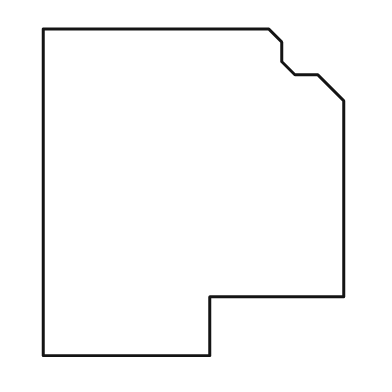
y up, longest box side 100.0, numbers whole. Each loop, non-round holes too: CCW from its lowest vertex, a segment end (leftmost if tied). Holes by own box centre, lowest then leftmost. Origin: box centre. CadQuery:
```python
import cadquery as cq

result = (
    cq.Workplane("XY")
    .moveTo(-46.0, -50.0)
    .lineTo(5.0, -50.0)
    .lineTo(5.0, -32.0)
    .lineTo(46.0, -32.0)
    .lineTo(46.0, 28.0)
    .lineTo(38.0, 36.0)
    .lineTo(31.0, 36.0)
    .lineTo(27.0, 40.0)
    .lineTo(27.0, 46.0)
    .lineTo(23.0, 50.0)
    .lineTo(-46.0, 50.0)
    .close()
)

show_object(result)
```